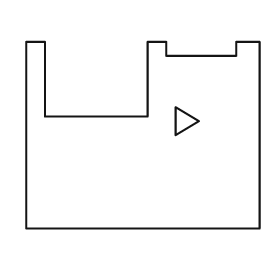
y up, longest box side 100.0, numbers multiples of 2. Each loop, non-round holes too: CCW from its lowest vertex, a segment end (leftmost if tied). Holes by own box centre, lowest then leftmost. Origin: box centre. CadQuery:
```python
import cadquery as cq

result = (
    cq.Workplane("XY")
    .moveTo(-50.0, -40.0)
    .lineTo(50.0, -40.0)
    .lineTo(50.0, 40.0)
    .lineTo(40.0, 40.0)
    .lineTo(40.0, 34.0)
    .lineTo(10.0, 34.0)
    .lineTo(10.0, 40.0)
    .lineTo(2.0, 40.0)
    .lineTo(2.0, 8.0)
    .lineTo(-42.0, 8.0)
    .lineTo(-42.0, 40.0)
    .lineTo(-50.0, 40.0)
    .close()
    .moveTo(14.0, 0.0)
    .lineTo(24.0, 6.0)
    .lineTo(14.0, 12.0)
    .close()
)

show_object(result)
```